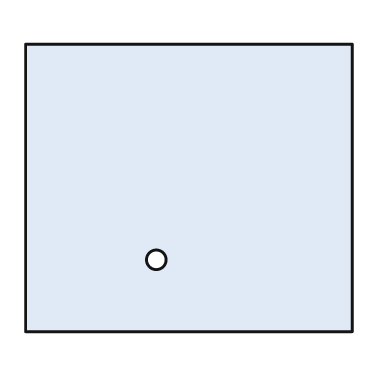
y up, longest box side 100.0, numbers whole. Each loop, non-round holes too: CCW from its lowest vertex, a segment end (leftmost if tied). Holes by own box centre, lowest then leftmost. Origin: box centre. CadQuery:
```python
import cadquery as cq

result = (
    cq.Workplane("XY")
    .moveTo(-50.0, -44.0)
    .lineTo(50.0, -44.0)
    .lineTo(50.0, 44.0)
    .lineTo(-50.0, 44.0)
    .close()
    .moveTo(-10.0, -22.0)
    .circle(3.0)
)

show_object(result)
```